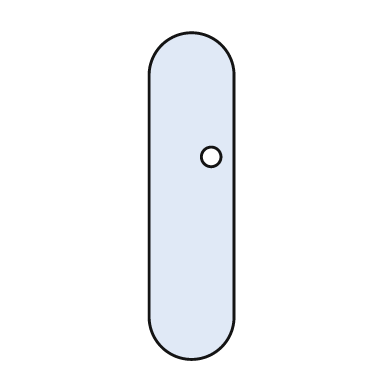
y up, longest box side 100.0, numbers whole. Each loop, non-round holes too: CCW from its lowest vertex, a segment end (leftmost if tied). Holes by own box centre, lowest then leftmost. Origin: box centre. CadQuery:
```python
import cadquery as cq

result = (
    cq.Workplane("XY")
    .moveTo(-13.0, -37.0)
    .threePointArc((0.0, -50.0), (13.0, -37.0))
    .lineTo(13.0, 37.0)
    .threePointArc((0.0, 50.0), (-13.0, 37.0))
    .close()
    .moveTo(6.0, 12.0)
    .circle(3.0)
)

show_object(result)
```